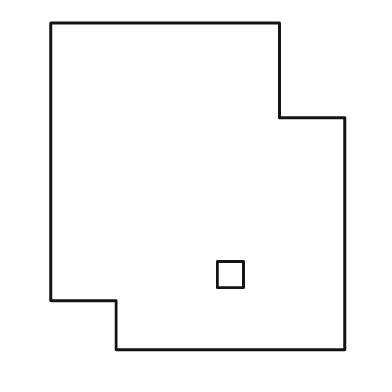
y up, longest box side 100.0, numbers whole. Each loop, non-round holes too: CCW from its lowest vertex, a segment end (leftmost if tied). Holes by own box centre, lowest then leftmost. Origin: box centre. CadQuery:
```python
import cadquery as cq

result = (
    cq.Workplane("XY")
    .moveTo(-25.0, -50.0)
    .lineTo(45.0, -50.0)
    .lineTo(45.0, 21.0)
    .lineTo(25.0, 21.0)
    .lineTo(25.0, 50.0)
    .lineTo(-45.0, 50.0)
    .lineTo(-45.0, -35.0)
    .lineTo(-25.0, -35.0)
    .close()
    .moveTo(6.0, -31.0)
    .lineTo(14.0, -31.0)
    .lineTo(14.0, -23.0)
    .lineTo(6.0, -23.0)
    .close()
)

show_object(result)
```